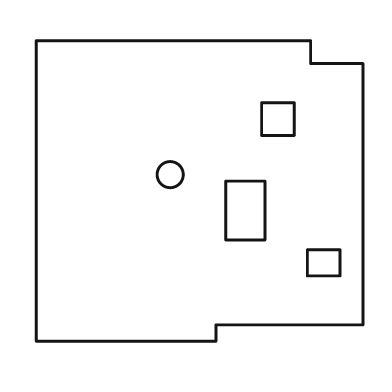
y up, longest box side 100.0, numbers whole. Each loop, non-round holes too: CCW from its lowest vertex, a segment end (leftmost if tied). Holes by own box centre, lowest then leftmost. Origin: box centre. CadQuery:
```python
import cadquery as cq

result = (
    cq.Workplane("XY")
    .moveTo(-50.0, -46.0)
    .lineTo(5.0, -46.0)
    .lineTo(5.0, -41.0)
    .lineTo(50.0, -41.0)
    .lineTo(50.0, 39.0)
    .lineTo(34.0, 39.0)
    .lineTo(34.0, 46.0)
    .lineTo(-50.0, 46.0)
    .close()
    .moveTo(33.0, -26.0)
    .lineTo(43.0, -26.0)
    .lineTo(43.0, -18.0)
    .lineTo(33.0, -18.0)
    .close()
    .moveTo(8.0, -15.0)
    .lineTo(20.0, -15.0)
    .lineTo(20.0, 3.0)
    .lineTo(8.0, 3.0)
    .close()
    .moveTo(-9.0, 5.0)
    .circle(4.0)
    .moveTo(19.0, 17.0)
    .lineTo(29.0, 17.0)
    .lineTo(29.0, 27.0)
    .lineTo(19.0, 27.0)
    .close()
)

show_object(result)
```